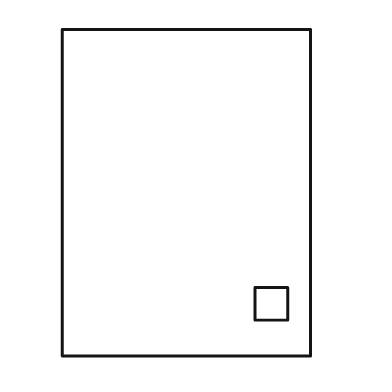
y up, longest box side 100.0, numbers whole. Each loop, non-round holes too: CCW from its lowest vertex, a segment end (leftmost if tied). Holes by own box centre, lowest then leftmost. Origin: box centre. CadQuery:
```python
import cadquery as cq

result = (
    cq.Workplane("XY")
    .moveTo(-38.0, -50.0)
    .lineTo(38.0, -50.0)
    .lineTo(38.0, 50.0)
    .lineTo(-38.0, 50.0)
    .close()
    .moveTo(21.0, -39.0)
    .lineTo(31.0, -39.0)
    .lineTo(31.0, -29.0)
    .lineTo(21.0, -29.0)
    .close()
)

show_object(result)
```